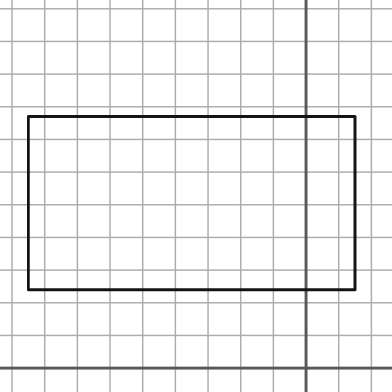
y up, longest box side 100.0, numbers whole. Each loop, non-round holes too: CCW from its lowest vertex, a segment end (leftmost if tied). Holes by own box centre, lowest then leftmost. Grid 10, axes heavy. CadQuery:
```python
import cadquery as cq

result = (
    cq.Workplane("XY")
    .moveTo(-85.0, 24.0)
    .lineTo(15.0, 24.0)
    .lineTo(15.0, 77.0)
    .lineTo(-85.0, 77.0)
    .close()
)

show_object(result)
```